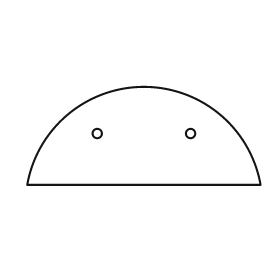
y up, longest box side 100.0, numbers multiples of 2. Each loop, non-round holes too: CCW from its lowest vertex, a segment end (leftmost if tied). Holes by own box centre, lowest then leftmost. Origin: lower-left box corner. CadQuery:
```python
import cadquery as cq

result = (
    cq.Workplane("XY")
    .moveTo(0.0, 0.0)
    .lineTo(100.0, 0.0)
    .threePointArc((50.0, 42.0), (0.0, 0.0))
    .close()
    .moveTo(30.0, 22.0)
    .circle(2.0)
    .moveTo(70.0, 22.0)
    .circle(2.0)
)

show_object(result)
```